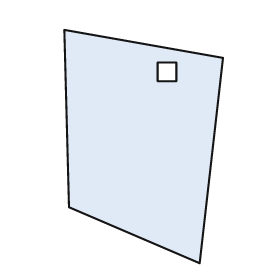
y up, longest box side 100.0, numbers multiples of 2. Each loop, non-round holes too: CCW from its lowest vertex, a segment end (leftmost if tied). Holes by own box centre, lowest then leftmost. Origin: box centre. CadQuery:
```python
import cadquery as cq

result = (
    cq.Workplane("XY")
    .moveTo(24.0, -50.0)
    .lineTo(34.0, 38.0)
    .lineTo(-34.0, 50.0)
    .lineTo(-32.0, -26.0)
    .close()
    .moveTo(6.0, 28.0)
    .lineTo(14.0, 28.0)
    .lineTo(14.0, 36.0)
    .lineTo(6.0, 36.0)
    .close()
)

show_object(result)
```